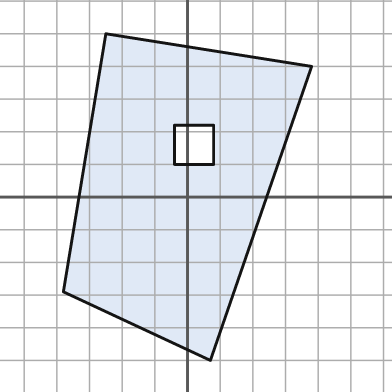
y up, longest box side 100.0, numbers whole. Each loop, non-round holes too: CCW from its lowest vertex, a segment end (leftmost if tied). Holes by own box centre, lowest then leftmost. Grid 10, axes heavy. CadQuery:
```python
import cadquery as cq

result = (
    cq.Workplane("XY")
    .moveTo(7.0, -50.0)
    .lineTo(38.0, 40.0)
    .lineTo(-25.0, 50.0)
    .lineTo(-38.0, -29.0)
    .close()
    .moveTo(-4.0, 10.0)
    .lineTo(8.0, 10.0)
    .lineTo(8.0, 22.0)
    .lineTo(-4.0, 22.0)
    .close()
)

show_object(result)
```